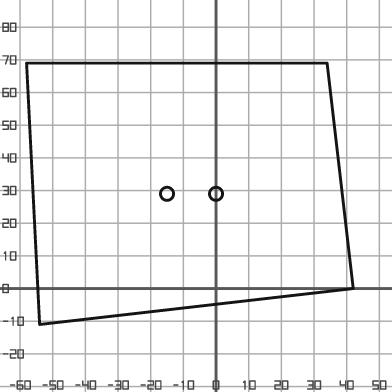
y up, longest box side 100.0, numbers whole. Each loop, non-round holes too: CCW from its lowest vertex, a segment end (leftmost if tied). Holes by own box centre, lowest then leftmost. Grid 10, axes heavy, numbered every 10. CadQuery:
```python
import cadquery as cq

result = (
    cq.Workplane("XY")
    .moveTo(-54.0, -11.0)
    .lineTo(42.0, 0.0)
    .lineTo(34.0, 69.0)
    .lineTo(-58.0, 69.0)
    .close()
    .moveTo(-15.0, 29.0)
    .circle(2.0)
    .moveTo(0.0, 29.0)
    .circle(2.0)
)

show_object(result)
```